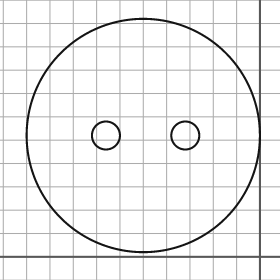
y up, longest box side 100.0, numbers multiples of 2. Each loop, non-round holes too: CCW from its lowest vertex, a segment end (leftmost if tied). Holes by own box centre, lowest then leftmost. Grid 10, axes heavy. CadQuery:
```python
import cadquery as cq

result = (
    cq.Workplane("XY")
    .moveTo(-50.0, 52.0)
    .circle(50.0)
    .moveTo(-66.0, 52.0)
    .circle(6.0)
    .moveTo(-32.0, 52.0)
    .circle(6.0)
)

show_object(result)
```